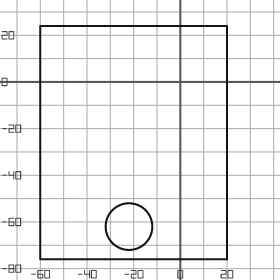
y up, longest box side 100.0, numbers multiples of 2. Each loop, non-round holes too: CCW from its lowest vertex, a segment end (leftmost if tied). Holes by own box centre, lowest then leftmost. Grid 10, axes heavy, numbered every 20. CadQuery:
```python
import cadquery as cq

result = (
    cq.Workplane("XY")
    .moveTo(-60.0, -76.0)
    .lineTo(20.0, -76.0)
    .lineTo(20.0, 24.0)
    .lineTo(-60.0, 24.0)
    .close()
    .moveTo(-22.0, -62.0)
    .circle(10.0)
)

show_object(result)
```